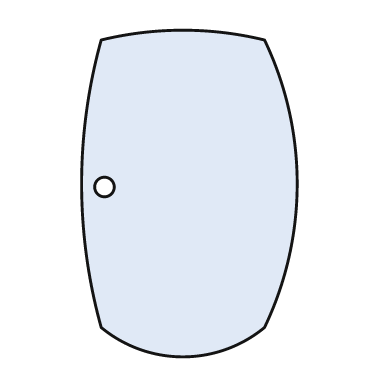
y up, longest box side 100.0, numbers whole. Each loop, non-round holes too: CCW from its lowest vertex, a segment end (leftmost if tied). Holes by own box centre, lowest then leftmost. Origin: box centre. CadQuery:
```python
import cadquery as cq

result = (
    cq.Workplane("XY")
    .moveTo(-27.0, -41.0)
    .threePointArc((-2.0, -50.0), (23.0, -41.0))
    .threePointArc((33.0, 3.0), (23.0, 47.0))
    .threePointArc((-2.0, 50.0), (-27.0, 47.0))
    .threePointArc((-33.0, 3.0), (-27.0, -41.0))
    .close()
    .moveTo(-26.0, 2.0)
    .circle(3.0)
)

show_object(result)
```